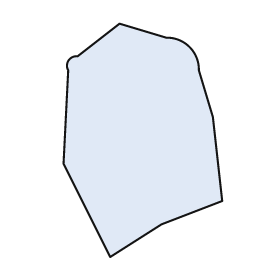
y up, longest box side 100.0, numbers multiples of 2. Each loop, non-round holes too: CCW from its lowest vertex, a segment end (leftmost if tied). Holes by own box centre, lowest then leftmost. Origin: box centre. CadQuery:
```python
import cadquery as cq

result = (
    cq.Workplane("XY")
    .moveTo(-14.0, -50.0)
    .lineTo(8.0, -36.0)
    .lineTo(34.0, -26.0)
    .lineTo(30.0, 10.0)
    .lineTo(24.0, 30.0)
    .threePointArc((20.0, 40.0), (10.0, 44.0))
    .lineTo(-10.0, 50.0)
    .lineTo(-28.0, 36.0)
    .threePointArc((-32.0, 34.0), (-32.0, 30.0))
    .lineTo(-34.0, -10.0)
    .close()
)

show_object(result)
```